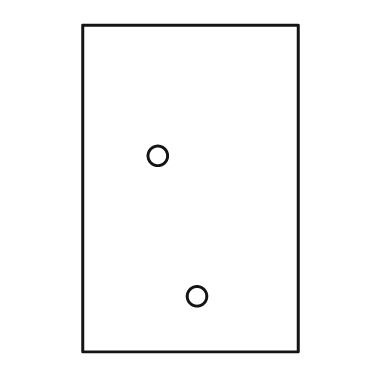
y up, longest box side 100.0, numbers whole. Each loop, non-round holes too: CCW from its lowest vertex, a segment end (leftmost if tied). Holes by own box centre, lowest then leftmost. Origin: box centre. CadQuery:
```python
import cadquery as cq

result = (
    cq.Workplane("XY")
    .moveTo(-33.0, -50.0)
    .lineTo(33.0, -50.0)
    .lineTo(33.0, 50.0)
    .lineTo(-33.0, 50.0)
    .close()
    .moveTo(2.0, -33.0)
    .circle(3.0)
    .moveTo(-10.0, 10.0)
    .circle(3.0)
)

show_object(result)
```